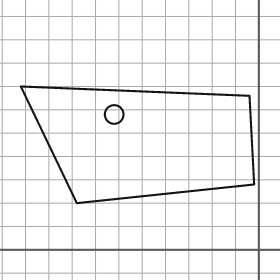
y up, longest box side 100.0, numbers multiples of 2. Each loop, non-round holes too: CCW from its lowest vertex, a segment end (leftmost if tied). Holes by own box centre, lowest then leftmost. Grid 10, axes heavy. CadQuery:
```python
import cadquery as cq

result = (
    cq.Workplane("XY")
    .moveTo(-78.0, 20.0)
    .lineTo(-2.0, 28.0)
    .lineTo(-4.0, 66.0)
    .lineTo(-102.0, 70.0)
    .close()
    .moveTo(-62.0, 58.0)
    .circle(4.0)
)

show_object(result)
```